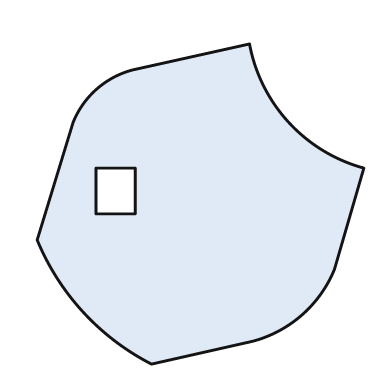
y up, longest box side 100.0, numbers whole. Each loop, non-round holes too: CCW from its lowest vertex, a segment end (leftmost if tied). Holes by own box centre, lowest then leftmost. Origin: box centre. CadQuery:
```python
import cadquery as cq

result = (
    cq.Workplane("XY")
    .moveTo(-15.0, -49.0)
    .lineTo(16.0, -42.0)
    .threePointArc((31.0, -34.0), (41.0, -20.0))
    .lineTo(50.0, 11.0)
    .threePointArc((27.0, 25.0), (15.0, 49.0))
    .lineTo(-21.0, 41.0)
    .threePointArc((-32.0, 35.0), (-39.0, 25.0))
    .lineTo(-50.0, -11.0)
    .threePointArc((-36.0, -33.0), (-15.0, -49.0))
    .close()
    .moveTo(-32.0, -3.0)
    .lineTo(-20.0, -3.0)
    .lineTo(-20.0, 11.0)
    .lineTo(-32.0, 11.0)
    .close()
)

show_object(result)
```